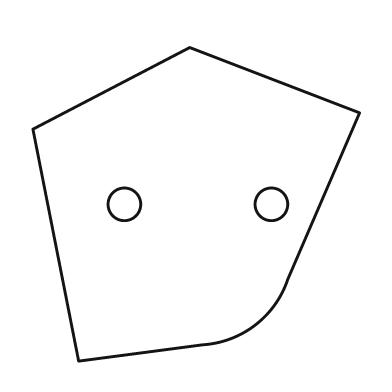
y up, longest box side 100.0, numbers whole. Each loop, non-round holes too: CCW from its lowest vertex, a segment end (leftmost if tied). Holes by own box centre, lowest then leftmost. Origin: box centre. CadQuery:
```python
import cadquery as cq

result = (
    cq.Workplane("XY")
    .moveTo(-36.0, -48.0)
    .lineTo(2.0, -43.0)
    .threePointArc((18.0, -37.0), (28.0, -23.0))
    .lineTo(50.0, 28.0)
    .lineTo(-2.0, 48.0)
    .lineTo(-50.0, 23.0)
    .close()
    .moveTo(-22.0, 0.0)
    .circle(5.0)
    .moveTo(23.0, 0.0)
    .circle(5.0)
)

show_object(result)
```